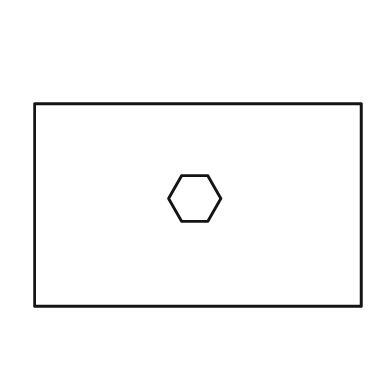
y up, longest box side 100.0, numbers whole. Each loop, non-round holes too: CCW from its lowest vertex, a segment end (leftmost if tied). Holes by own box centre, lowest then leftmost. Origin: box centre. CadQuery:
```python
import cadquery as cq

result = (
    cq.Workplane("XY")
    .moveTo(-50.0, -31.0)
    .lineTo(50.0, -31.0)
    .lineTo(50.0, 31.0)
    .lineTo(-50.0, 31.0)
    .close()
    .moveTo(-5.0, -5.0)
    .lineTo(3.0, -5.0)
    .lineTo(7.0, 2.0)
    .lineTo(3.0, 9.0)
    .lineTo(-5.0, 9.0)
    .lineTo(-9.0, 2.0)
    .close()
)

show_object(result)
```